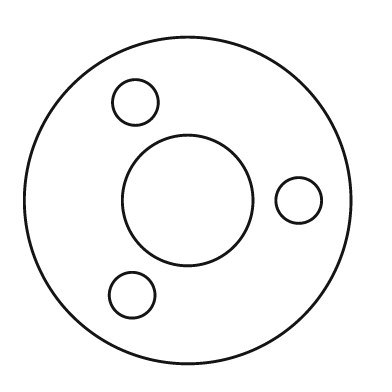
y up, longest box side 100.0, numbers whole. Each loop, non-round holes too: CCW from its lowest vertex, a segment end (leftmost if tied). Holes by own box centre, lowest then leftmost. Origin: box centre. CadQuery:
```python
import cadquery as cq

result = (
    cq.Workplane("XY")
    .moveTo(0.0, 0.0)
    .circle(50.0)
    .moveTo(-17.0, -29.0)
    .circle(7.0)
    .moveTo(0.0, 0.0)
    .circle(20.0)
    .moveTo(34.0, 0.0)
    .circle(7.0)
    .moveTo(-16.0, 30.0)
    .circle(7.0)
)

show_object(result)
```